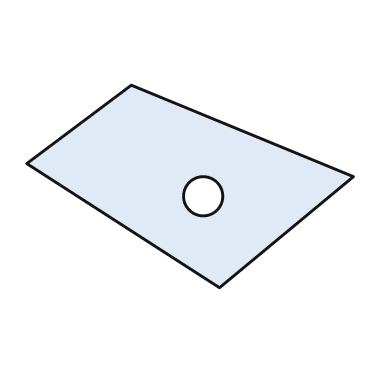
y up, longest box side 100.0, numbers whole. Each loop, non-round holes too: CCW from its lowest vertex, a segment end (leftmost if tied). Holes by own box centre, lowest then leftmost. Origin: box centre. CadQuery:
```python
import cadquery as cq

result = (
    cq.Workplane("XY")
    .moveTo(9.0, -31.0)
    .lineTo(50.0, 3.0)
    .lineTo(-18.0, 31.0)
    .lineTo(-50.0, 7.0)
    .close()
    .moveTo(4.0, -3.0)
    .circle(6.0)
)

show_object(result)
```